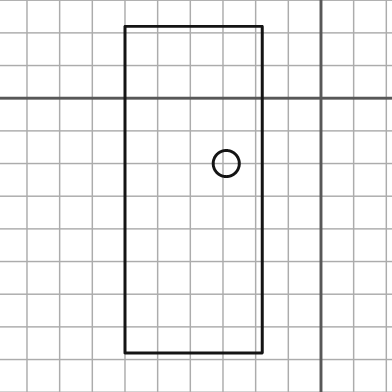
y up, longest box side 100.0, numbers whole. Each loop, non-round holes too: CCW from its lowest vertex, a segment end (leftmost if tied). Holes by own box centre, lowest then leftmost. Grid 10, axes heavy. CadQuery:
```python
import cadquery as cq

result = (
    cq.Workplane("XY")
    .moveTo(-60.0, -78.0)
    .lineTo(-18.0, -78.0)
    .lineTo(-18.0, 22.0)
    .lineTo(-60.0, 22.0)
    .close()
    .moveTo(-29.0, -20.0)
    .circle(4.0)
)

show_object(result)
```